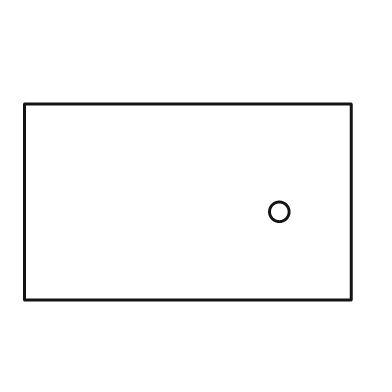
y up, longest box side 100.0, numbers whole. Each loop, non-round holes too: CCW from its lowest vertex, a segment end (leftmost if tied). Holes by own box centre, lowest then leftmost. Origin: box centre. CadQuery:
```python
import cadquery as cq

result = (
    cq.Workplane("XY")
    .moveTo(-50.0, -30.0)
    .lineTo(50.0, -30.0)
    .lineTo(50.0, 30.0)
    .lineTo(-50.0, 30.0)
    .close()
    .moveTo(28.0, -3.0)
    .circle(3.0)
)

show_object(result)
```